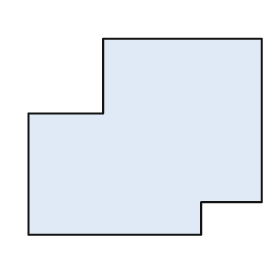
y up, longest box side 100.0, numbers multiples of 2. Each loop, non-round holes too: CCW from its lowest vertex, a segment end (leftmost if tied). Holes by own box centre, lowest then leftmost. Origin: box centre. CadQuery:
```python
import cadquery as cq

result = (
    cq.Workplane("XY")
    .moveTo(-50.0, -42.0)
    .lineTo(24.0, -42.0)
    .lineTo(24.0, -28.0)
    .lineTo(50.0, -28.0)
    .lineTo(50.0, 42.0)
    .lineTo(-18.0, 42.0)
    .lineTo(-18.0, 10.0)
    .lineTo(-50.0, 10.0)
    .close()
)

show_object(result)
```